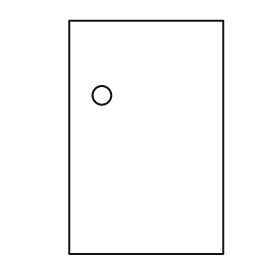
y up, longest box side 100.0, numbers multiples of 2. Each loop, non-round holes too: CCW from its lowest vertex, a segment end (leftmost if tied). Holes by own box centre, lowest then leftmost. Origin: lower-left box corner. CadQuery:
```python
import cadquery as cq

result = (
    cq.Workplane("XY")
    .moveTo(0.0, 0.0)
    .lineTo(66.0, 0.0)
    .lineTo(66.0, 100.0)
    .lineTo(0.0, 100.0)
    .close()
    .moveTo(14.0, 68.0)
    .circle(4.0)
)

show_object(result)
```